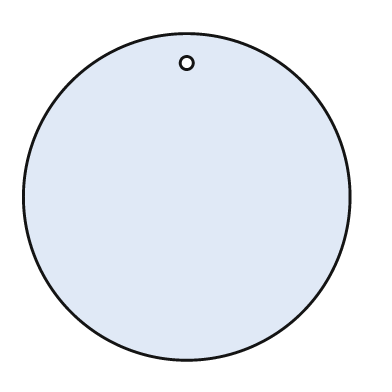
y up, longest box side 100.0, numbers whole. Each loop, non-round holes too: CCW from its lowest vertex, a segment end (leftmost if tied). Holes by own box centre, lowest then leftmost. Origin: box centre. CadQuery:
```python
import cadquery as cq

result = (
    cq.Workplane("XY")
    .moveTo(0.0, 0.0)
    .circle(50.0)
    .moveTo(0.0, 41.0)
    .circle(2.0)
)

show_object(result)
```